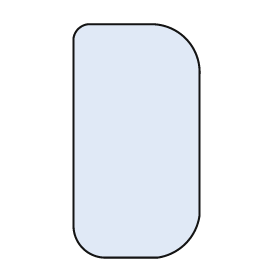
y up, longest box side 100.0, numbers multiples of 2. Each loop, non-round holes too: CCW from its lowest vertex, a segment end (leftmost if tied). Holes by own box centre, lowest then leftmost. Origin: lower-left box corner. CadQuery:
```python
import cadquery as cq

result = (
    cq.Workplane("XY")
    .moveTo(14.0, 0.0)
    .lineTo(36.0, 0.0)
    .threePointArc((48.0, 6.0), (54.0, 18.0))
    .lineTo(54.0, 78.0)
    .threePointArc((48.0, 94.0), (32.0, 100.0))
    .lineTo(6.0, 100.0)
    .threePointArc((2.0, 98.0), (0.0, 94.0))
    .lineTo(0.0, 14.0)
    .threePointArc((4.0, 4.0), (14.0, 0.0))
    .close()
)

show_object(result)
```